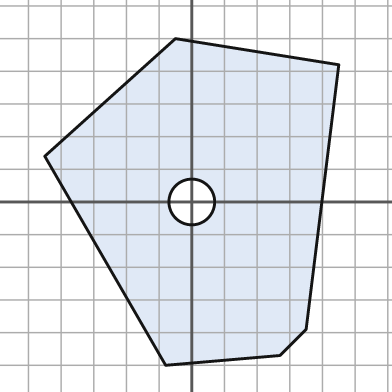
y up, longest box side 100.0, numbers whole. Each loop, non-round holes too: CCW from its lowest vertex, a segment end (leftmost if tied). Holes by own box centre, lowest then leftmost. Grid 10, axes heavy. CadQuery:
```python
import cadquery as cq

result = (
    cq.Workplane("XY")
    .moveTo(-8.0, -50.0)
    .lineTo(27.0, -47.0)
    .lineTo(35.0, -39.0)
    .lineTo(45.0, 42.0)
    .lineTo(-5.0, 50.0)
    .lineTo(-45.0, 14.0)
    .close()
    .moveTo(0.0, 0.0)
    .circle(7.0)
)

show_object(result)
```